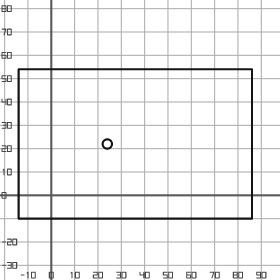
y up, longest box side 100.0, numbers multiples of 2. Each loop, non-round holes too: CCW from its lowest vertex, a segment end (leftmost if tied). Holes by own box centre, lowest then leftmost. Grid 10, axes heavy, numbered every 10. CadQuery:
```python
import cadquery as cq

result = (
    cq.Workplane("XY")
    .moveTo(-14.0, -10.0)
    .lineTo(86.0, -10.0)
    .lineTo(86.0, 54.0)
    .lineTo(-14.0, 54.0)
    .close()
    .moveTo(24.0, 22.0)
    .circle(2.0)
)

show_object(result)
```